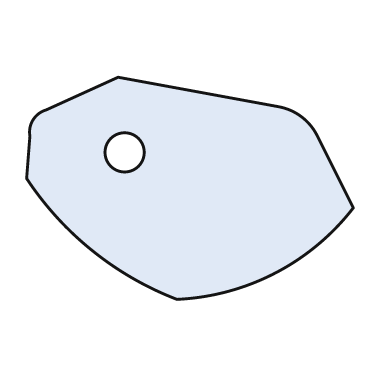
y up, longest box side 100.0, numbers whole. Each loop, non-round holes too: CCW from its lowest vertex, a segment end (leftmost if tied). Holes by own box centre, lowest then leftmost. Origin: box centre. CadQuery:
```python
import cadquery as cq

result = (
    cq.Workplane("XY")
    .moveTo(-4.0, -34.0)
    .threePointArc((26.0, -26.0), (50.0, -6.0))
    .lineTo(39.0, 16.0)
    .threePointArc((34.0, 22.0), (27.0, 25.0))
    .lineTo(-22.0, 34.0)
    .lineTo(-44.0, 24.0)
    .threePointArc((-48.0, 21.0), (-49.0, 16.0))
    .lineTo(-50.0, 3.0)
    .threePointArc((-30.0, -19.0), (-4.0, -34.0))
    .close()
    .moveTo(-20.0, 11.0)
    .circle(6.0)
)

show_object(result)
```